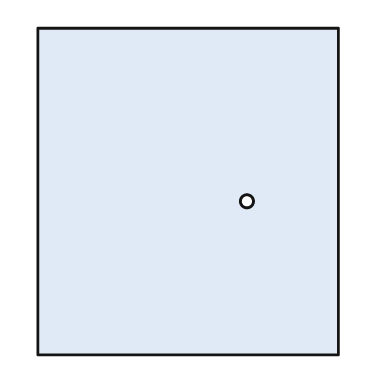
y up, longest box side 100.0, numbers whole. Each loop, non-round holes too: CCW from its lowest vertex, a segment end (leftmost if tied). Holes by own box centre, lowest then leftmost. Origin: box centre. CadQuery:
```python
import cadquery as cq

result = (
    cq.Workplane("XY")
    .moveTo(-46.0, -50.0)
    .lineTo(46.0, -50.0)
    .lineTo(46.0, 50.0)
    .lineTo(-46.0, 50.0)
    .close()
    .moveTo(18.0, -3.0)
    .circle(2.0)
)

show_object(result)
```